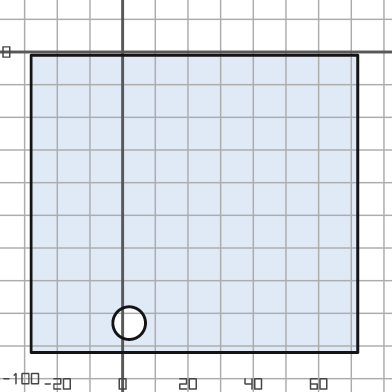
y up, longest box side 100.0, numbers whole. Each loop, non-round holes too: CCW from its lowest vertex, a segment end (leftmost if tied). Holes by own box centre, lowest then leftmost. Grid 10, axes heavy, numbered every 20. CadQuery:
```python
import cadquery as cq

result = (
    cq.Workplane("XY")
    .moveTo(-28.0, -92.0)
    .lineTo(72.0, -92.0)
    .lineTo(72.0, -1.0)
    .lineTo(-28.0, -1.0)
    .close()
    .moveTo(2.0, -83.0)
    .circle(5.0)
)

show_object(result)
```